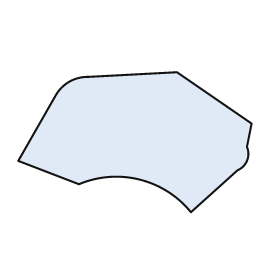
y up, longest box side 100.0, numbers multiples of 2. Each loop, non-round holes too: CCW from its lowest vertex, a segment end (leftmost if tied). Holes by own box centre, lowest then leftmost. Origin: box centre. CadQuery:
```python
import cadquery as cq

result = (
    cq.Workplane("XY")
    .moveTo(24.0, -30.0)
    .lineTo(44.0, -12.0)
    .threePointArc((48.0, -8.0), (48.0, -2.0))
    .lineTo(50.0, 8.0)
    .lineTo(18.0, 30.0)
    .lineTo(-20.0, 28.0)
    .threePointArc((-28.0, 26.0), (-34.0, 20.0))
    .lineTo(-50.0, -8.0)
    .lineTo(-24.0, -18.0)
    .threePointArc((2.0, -16.0), (24.0, -30.0))
    .close()
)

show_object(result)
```